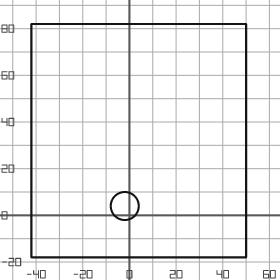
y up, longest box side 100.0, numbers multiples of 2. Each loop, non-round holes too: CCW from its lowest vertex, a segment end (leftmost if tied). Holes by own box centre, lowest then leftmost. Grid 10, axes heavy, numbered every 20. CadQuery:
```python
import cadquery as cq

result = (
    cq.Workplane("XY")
    .moveTo(-42.0, -18.0)
    .lineTo(50.0, -18.0)
    .lineTo(50.0, 82.0)
    .lineTo(-42.0, 82.0)
    .close()
    .moveTo(-2.0, 4.0)
    .circle(6.0)
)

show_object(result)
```